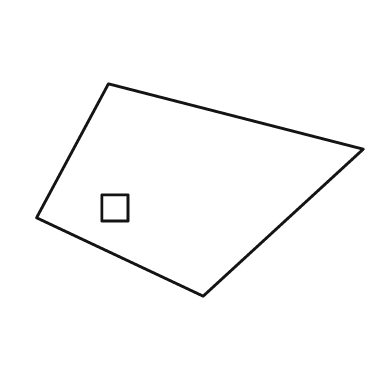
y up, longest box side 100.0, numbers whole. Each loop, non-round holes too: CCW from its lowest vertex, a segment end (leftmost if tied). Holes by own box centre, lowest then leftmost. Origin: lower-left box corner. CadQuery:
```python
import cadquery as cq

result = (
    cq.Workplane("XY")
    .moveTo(51.0, 0.0)
    .lineTo(100.0, 45.0)
    .lineTo(22.0, 65.0)
    .lineTo(0.0, 24.0)
    .close()
    .moveTo(20.0, 23.0)
    .lineTo(28.0, 23.0)
    .lineTo(28.0, 31.0)
    .lineTo(20.0, 31.0)
    .close()
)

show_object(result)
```